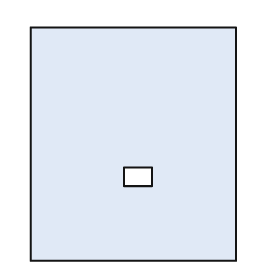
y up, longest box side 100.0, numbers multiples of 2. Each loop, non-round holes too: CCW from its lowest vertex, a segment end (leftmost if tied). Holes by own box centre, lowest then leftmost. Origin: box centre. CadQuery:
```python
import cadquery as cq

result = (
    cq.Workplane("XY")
    .moveTo(-44.0, -50.0)
    .lineTo(44.0, -50.0)
    .lineTo(44.0, 50.0)
    .lineTo(-44.0, 50.0)
    .close()
    .moveTo(-4.0, -18.0)
    .lineTo(8.0, -18.0)
    .lineTo(8.0, -10.0)
    .lineTo(-4.0, -10.0)
    .close()
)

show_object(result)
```